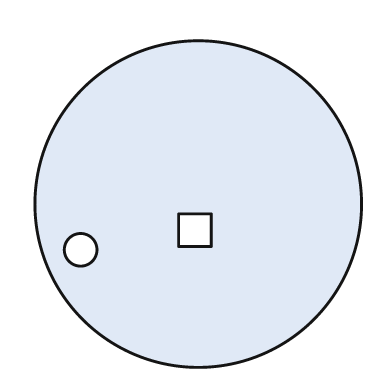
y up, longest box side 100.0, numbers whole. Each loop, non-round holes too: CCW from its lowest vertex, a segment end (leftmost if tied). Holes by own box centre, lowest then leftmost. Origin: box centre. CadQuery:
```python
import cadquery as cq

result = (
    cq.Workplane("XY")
    .moveTo(0.0, 0.0)
    .circle(50.0)
    .moveTo(-36.0, -14.0)
    .circle(5.0)
    .moveTo(-6.0, -13.0)
    .lineTo(4.0, -13.0)
    .lineTo(4.0, -3.0)
    .lineTo(-6.0, -3.0)
    .close()
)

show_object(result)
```